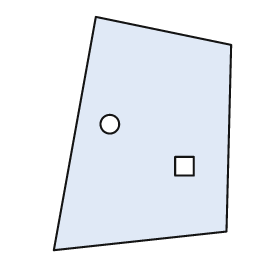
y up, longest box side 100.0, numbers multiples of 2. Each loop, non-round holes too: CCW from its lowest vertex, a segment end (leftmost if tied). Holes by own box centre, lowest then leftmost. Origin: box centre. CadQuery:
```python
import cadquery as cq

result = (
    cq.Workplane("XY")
    .moveTo(-38.0, -50.0)
    .lineTo(36.0, -42.0)
    .lineTo(38.0, 38.0)
    .lineTo(-20.0, 50.0)
    .close()
    .moveTo(14.0, -18.0)
    .lineTo(22.0, -18.0)
    .lineTo(22.0, -10.0)
    .lineTo(14.0, -10.0)
    .close()
    .moveTo(-14.0, 4.0)
    .circle(4.0)
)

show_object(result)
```